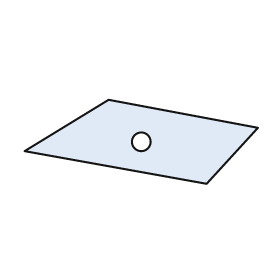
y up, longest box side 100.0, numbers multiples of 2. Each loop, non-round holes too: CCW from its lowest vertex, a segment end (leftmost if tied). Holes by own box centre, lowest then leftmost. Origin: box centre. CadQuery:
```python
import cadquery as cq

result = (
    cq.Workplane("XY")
    .moveTo(28.0, -18.0)
    .lineTo(50.0, 6.0)
    .lineTo(-14.0, 18.0)
    .lineTo(-50.0, -4.0)
    .close()
    .moveTo(0.0, 0.0)
    .circle(4.0)
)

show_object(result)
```